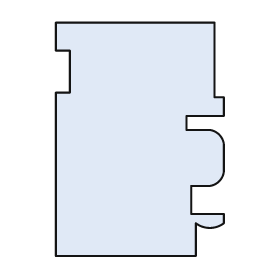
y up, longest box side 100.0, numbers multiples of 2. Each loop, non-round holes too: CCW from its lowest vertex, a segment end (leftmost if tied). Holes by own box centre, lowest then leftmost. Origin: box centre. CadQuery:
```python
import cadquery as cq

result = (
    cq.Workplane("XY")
    .moveTo(-36.0, -50.0)
    .lineTo(24.0, -50.0)
    .lineTo(24.0, -36.0)
    .threePointArc((30.0, -38.0), (36.0, -36.0))
    .lineTo(36.0, -32.0)
    .lineTo(22.0, -32.0)
    .lineTo(22.0, -20.0)
    .lineTo(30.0, -20.0)
    .threePointArc((34.0, -18.0), (36.0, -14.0))
    .lineTo(36.0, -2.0)
    .threePointArc((34.0, 2.0), (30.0, 4.0))
    .lineTo(20.0, 4.0)
    .lineTo(20.0, 10.0)
    .lineTo(36.0, 10.0)
    .lineTo(36.0, 18.0)
    .lineTo(32.0, 18.0)
    .lineTo(32.0, 50.0)
    .lineTo(-36.0, 50.0)
    .lineTo(-36.0, 38.0)
    .lineTo(-30.0, 38.0)
    .lineTo(-30.0, 20.0)
    .lineTo(-36.0, 20.0)
    .close()
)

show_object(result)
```